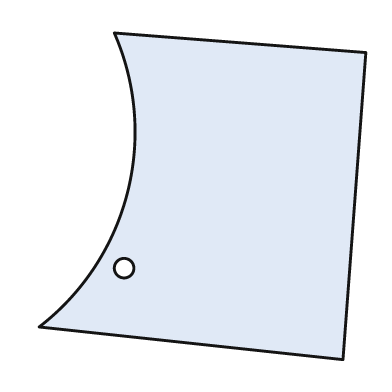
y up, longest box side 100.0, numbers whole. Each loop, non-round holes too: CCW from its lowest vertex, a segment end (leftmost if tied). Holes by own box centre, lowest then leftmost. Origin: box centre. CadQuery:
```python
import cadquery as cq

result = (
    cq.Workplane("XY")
    .moveTo(43.0, -50.0)
    .lineTo(50.0, 44.0)
    .lineTo(-27.0, 50.0)
    .threePointArc((-23.0, 1.0), (-50.0, -40.0))
    .close()
    .moveTo(-24.0, -22.0)
    .circle(3.0)
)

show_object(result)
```